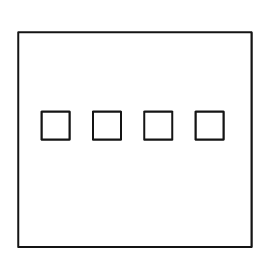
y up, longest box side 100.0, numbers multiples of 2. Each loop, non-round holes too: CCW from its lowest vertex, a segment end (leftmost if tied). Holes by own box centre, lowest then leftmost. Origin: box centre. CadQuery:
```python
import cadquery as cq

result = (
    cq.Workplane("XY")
    .moveTo(-50.0, -46.0)
    .lineTo(50.0, -46.0)
    .lineTo(50.0, 46.0)
    .lineTo(-50.0, 46.0)
    .close()
    .moveTo(-40.0, 0.0)
    .lineTo(-28.0, 0.0)
    .lineTo(-28.0, 12.0)
    .lineTo(-40.0, 12.0)
    .close()
    .moveTo(-18.0, 0.0)
    .lineTo(-6.0, 0.0)
    .lineTo(-6.0, 12.0)
    .lineTo(-18.0, 12.0)
    .close()
    .moveTo(4.0, 0.0)
    .lineTo(16.0, 0.0)
    .lineTo(16.0, 12.0)
    .lineTo(4.0, 12.0)
    .close()
    .moveTo(26.0, 0.0)
    .lineTo(38.0, 0.0)
    .lineTo(38.0, 12.0)
    .lineTo(26.0, 12.0)
    .close()
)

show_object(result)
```